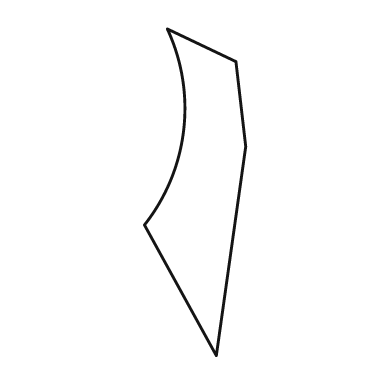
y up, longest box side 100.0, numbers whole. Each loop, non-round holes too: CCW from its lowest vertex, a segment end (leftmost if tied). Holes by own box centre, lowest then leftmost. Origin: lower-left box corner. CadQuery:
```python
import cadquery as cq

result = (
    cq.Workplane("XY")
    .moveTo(22.0, 0.0)
    .lineTo(31.0, 64.0)
    .lineTo(28.0, 90.0)
    .lineTo(7.0, 100.0)
    .threePointArc((12.0, 69.0), (0.0, 40.0))
    .close()
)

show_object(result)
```